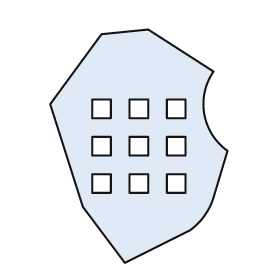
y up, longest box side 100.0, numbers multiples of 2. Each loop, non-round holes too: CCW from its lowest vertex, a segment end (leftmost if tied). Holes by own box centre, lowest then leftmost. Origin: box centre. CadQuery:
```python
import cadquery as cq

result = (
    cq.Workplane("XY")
    .moveTo(-6.0, -50.0)
    .lineTo(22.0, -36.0)
    .threePointArc((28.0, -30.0), (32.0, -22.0))
    .lineTo(38.0, -2.0)
    .threePointArc((28.0, 14.0), (32.0, 32.0))
    .lineTo(4.0, 50.0)
    .lineTo(-16.0, 48.0)
    .lineTo(-38.0, 18.0)
    .lineTo(-24.0, -26.0)
    .close()
    .moveTo(-20.0, -20.0)
    .lineTo(-12.0, -20.0)
    .lineTo(-12.0, -12.0)
    .lineTo(-20.0, -12.0)
    .close()
    .moveTo(-4.0, -20.0)
    .lineTo(4.0, -20.0)
    .lineTo(4.0, -12.0)
    .lineTo(-4.0, -12.0)
    .close()
    .moveTo(12.0, -20.0)
    .lineTo(20.0, -20.0)
    .lineTo(20.0, -12.0)
    .lineTo(12.0, -12.0)
    .close()
    .moveTo(-20.0, -4.0)
    .lineTo(-12.0, -4.0)
    .lineTo(-12.0, 4.0)
    .lineTo(-20.0, 4.0)
    .close()
    .moveTo(-4.0, -4.0)
    .lineTo(4.0, -4.0)
    .lineTo(4.0, 4.0)
    .lineTo(-4.0, 4.0)
    .close()
    .moveTo(12.0, -4.0)
    .lineTo(20.0, -4.0)
    .lineTo(20.0, 4.0)
    .lineTo(12.0, 4.0)
    .close()
    .moveTo(-20.0, 12.0)
    .lineTo(-12.0, 12.0)
    .lineTo(-12.0, 20.0)
    .lineTo(-20.0, 20.0)
    .close()
    .moveTo(-4.0, 12.0)
    .lineTo(4.0, 12.0)
    .lineTo(4.0, 20.0)
    .lineTo(-4.0, 20.0)
    .close()
    .moveTo(12.0, 12.0)
    .lineTo(20.0, 12.0)
    .lineTo(20.0, 20.0)
    .lineTo(12.0, 20.0)
    .close()
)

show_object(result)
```